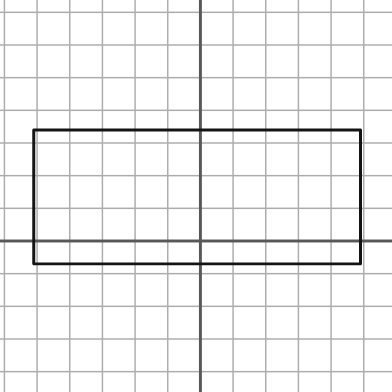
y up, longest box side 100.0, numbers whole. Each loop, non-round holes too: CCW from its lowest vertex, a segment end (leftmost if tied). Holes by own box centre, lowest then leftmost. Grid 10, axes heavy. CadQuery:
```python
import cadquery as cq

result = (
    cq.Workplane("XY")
    .moveTo(-51.0, -7.0)
    .lineTo(49.0, -7.0)
    .lineTo(49.0, 34.0)
    .lineTo(-51.0, 34.0)
    .close()
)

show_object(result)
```